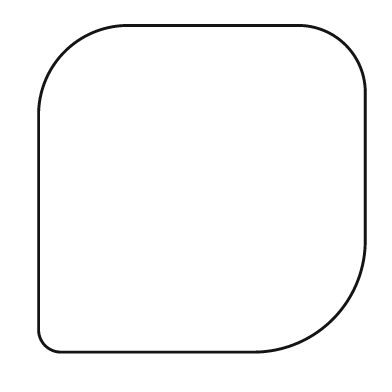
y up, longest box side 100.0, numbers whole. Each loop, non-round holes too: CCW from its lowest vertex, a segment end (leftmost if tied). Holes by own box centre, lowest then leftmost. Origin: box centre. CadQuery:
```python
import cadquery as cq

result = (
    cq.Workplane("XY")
    .moveTo(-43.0, -50.0)
    .lineTo(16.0, -50.0)
    .threePointArc((40.0, -40.0), (50.0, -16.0))
    .lineTo(50.0, 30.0)
    .threePointArc((44.0, 44.0), (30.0, 50.0))
    .lineTo(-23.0, 50.0)
    .threePointArc((-42.0, 42.0), (-50.0, 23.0))
    .lineTo(-50.0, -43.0)
    .threePointArc((-48.0, -48.0), (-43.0, -50.0))
    .close()
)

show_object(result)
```